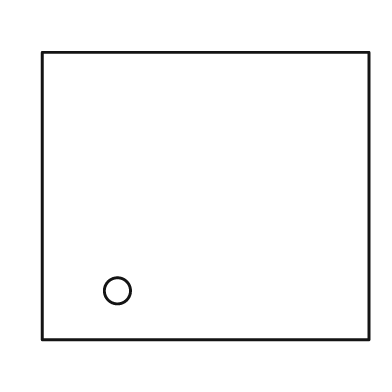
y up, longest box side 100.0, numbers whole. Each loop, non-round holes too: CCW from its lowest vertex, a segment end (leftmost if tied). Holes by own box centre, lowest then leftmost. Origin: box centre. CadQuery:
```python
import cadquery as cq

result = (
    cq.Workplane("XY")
    .moveTo(-50.0, -44.0)
    .lineTo(50.0, -44.0)
    .lineTo(50.0, 44.0)
    .lineTo(-50.0, 44.0)
    .close()
    .moveTo(-27.0, -29.0)
    .circle(4.0)
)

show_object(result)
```